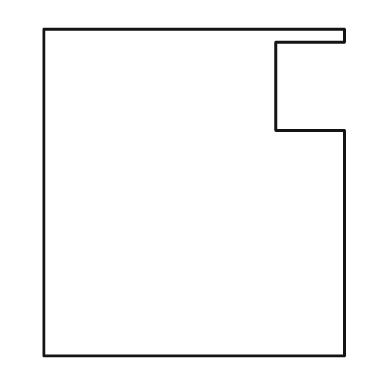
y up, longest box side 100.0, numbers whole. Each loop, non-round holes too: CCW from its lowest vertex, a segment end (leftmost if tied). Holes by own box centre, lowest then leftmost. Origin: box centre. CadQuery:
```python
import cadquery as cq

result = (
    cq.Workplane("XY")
    .moveTo(-46.0, -50.0)
    .lineTo(46.0, -50.0)
    .lineTo(46.0, 19.0)
    .lineTo(25.0, 19.0)
    .lineTo(25.0, 46.0)
    .lineTo(46.0, 46.0)
    .lineTo(46.0, 50.0)
    .lineTo(-46.0, 50.0)
    .close()
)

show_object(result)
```